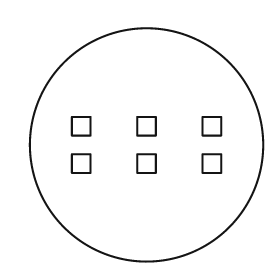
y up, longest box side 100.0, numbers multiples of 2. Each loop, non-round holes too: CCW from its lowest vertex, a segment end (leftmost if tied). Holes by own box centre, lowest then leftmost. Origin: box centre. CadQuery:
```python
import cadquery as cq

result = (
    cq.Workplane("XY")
    .moveTo(0.0, 0.0)
    .circle(50.0)
    .moveTo(-32.0, -12.0)
    .lineTo(-24.0, -12.0)
    .lineTo(-24.0, -4.0)
    .lineTo(-32.0, -4.0)
    .close()
    .moveTo(-4.0, -12.0)
    .lineTo(4.0, -12.0)
    .lineTo(4.0, -4.0)
    .lineTo(-4.0, -4.0)
    .close()
    .moveTo(24.0, -12.0)
    .lineTo(32.0, -12.0)
    .lineTo(32.0, -4.0)
    .lineTo(24.0, -4.0)
    .close()
    .moveTo(-32.0, 4.0)
    .lineTo(-24.0, 4.0)
    .lineTo(-24.0, 12.0)
    .lineTo(-32.0, 12.0)
    .close()
    .moveTo(-4.0, 4.0)
    .lineTo(4.0, 4.0)
    .lineTo(4.0, 12.0)
    .lineTo(-4.0, 12.0)
    .close()
    .moveTo(24.0, 4.0)
    .lineTo(32.0, 4.0)
    .lineTo(32.0, 12.0)
    .lineTo(24.0, 12.0)
    .close()
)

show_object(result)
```